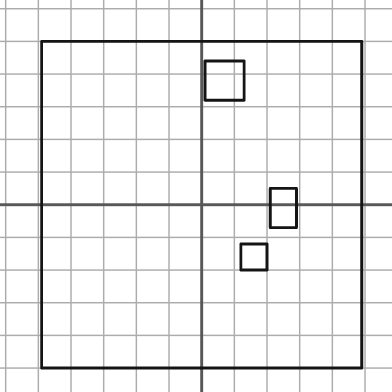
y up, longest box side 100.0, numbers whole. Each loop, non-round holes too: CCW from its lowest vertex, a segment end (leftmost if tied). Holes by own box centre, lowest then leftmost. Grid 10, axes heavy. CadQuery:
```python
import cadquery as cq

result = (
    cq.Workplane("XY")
    .moveTo(-49.0, -50.0)
    .lineTo(49.0, -50.0)
    .lineTo(49.0, 50.0)
    .lineTo(-49.0, 50.0)
    .close()
    .moveTo(12.0, -20.0)
    .lineTo(20.0, -20.0)
    .lineTo(20.0, -12.0)
    .lineTo(12.0, -12.0)
    .close()
    .moveTo(21.0, -7.0)
    .lineTo(29.0, -7.0)
    .lineTo(29.0, 5.0)
    .lineTo(21.0, 5.0)
    .close()
    .moveTo(1.0, 32.0)
    .lineTo(13.0, 32.0)
    .lineTo(13.0, 44.0)
    .lineTo(1.0, 44.0)
    .close()
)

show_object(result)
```